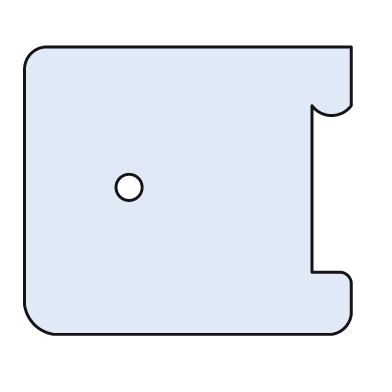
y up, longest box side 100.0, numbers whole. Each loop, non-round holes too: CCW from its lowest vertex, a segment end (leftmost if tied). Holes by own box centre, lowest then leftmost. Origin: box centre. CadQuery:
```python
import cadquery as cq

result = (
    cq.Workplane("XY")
    .moveTo(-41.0, -44.0)
    .lineTo(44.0, -44.0)
    .threePointArc((48.0, -42.0), (50.0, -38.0))
    .lineTo(50.0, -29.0)
    .threePointArc((49.0, -26.0), (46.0, -25.0))
    .lineTo(38.0, -25.0)
    .lineTo(38.0, 26.0)
    .threePointArc((44.0, 23.0), (50.0, 26.0))
    .lineTo(50.0, 44.0)
    .lineTo(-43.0, 44.0)
    .threePointArc((-48.0, 42.0), (-50.0, 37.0))
    .lineTo(-50.0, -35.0)
    .threePointArc((-47.0, -41.0), (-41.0, -44.0))
    .close()
    .moveTo(-18.0, 1.0)
    .circle(4.0)
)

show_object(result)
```